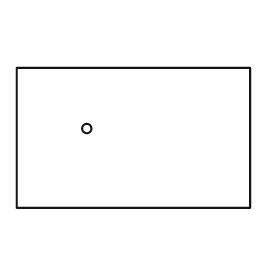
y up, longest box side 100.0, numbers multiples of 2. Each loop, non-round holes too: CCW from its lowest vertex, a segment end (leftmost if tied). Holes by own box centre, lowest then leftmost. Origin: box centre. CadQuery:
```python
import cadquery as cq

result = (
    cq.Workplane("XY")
    .moveTo(-50.0, -30.0)
    .lineTo(50.0, -30.0)
    .lineTo(50.0, 30.0)
    .lineTo(-50.0, 30.0)
    .close()
    .moveTo(-20.0, 4.0)
    .circle(2.0)
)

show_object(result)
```